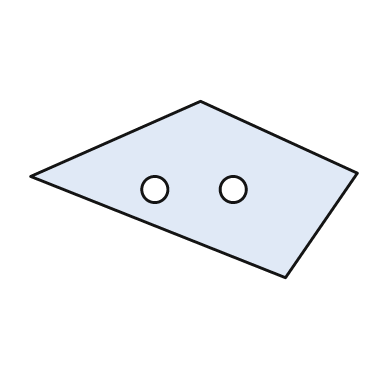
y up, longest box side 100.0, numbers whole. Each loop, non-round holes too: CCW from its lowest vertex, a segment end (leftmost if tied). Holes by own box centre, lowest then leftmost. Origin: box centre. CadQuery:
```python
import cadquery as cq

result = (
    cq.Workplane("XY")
    .moveTo(28.0, -27.0)
    .lineTo(50.0, 5.0)
    .lineTo(2.0, 27.0)
    .lineTo(-50.0, 4.0)
    .close()
    .moveTo(-12.0, 0.0)
    .circle(4.0)
    .moveTo(12.0, 0.0)
    .circle(4.0)
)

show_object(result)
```